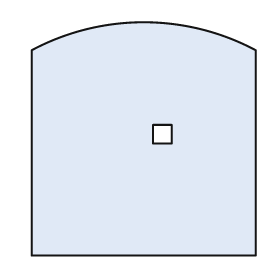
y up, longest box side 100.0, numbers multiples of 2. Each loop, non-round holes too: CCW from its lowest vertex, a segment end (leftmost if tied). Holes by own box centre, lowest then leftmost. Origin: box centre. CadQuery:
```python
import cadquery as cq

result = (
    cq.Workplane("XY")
    .moveTo(-48.0, -50.0)
    .lineTo(48.0, -50.0)
    .lineTo(48.0, 38.0)
    .threePointArc((0.0, 50.0), (-48.0, 38.0))
    .close()
    .moveTo(4.0, -2.0)
    .lineTo(12.0, -2.0)
    .lineTo(12.0, 6.0)
    .lineTo(4.0, 6.0)
    .close()
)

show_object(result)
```